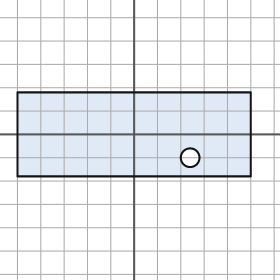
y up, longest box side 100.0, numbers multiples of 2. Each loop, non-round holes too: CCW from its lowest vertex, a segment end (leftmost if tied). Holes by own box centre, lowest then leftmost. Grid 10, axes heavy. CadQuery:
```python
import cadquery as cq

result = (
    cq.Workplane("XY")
    .moveTo(-50.0, -18.0)
    .lineTo(50.0, -18.0)
    .lineTo(50.0, 18.0)
    .lineTo(-50.0, 18.0)
    .close()
    .moveTo(24.0, -10.0)
    .circle(4.0)
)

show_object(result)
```